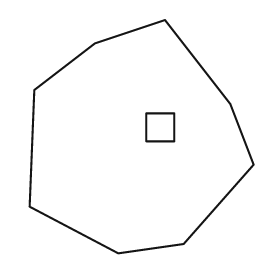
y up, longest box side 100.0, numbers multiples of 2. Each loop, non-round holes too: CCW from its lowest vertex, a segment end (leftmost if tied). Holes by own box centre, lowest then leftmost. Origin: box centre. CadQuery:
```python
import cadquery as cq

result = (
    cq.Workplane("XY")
    .moveTo(-10.0, -50.0)
    .lineTo(18.0, -46.0)
    .lineTo(48.0, -12.0)
    .lineTo(38.0, 14.0)
    .lineTo(10.0, 50.0)
    .lineTo(-20.0, 40.0)
    .lineTo(-46.0, 20.0)
    .lineTo(-48.0, -30.0)
    .close()
    .moveTo(2.0, -2.0)
    .lineTo(14.0, -2.0)
    .lineTo(14.0, 10.0)
    .lineTo(2.0, 10.0)
    .close()
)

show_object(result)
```